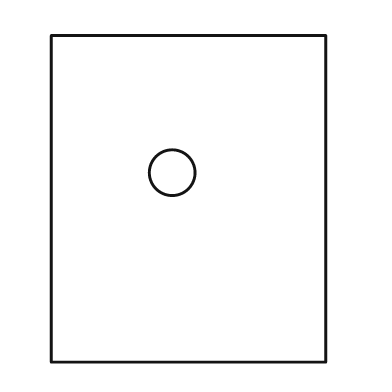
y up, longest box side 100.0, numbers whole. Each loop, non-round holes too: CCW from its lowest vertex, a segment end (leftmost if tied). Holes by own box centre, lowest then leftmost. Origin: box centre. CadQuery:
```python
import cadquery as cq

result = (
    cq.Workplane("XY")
    .moveTo(-42.0, -50.0)
    .lineTo(42.0, -50.0)
    .lineTo(42.0, 50.0)
    .lineTo(-42.0, 50.0)
    .close()
    .moveTo(-5.0, 8.0)
    .circle(7.0)
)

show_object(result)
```